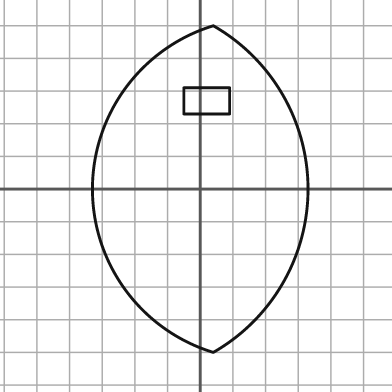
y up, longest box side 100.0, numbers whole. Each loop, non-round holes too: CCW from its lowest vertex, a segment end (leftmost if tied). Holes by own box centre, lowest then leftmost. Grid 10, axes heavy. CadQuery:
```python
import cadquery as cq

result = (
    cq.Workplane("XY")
    .moveTo(4.0, -50.0)
    .threePointArc((33.0, 0.0), (4.0, 50.0))
    .threePointArc((-33.0, 0.0), (4.0, -50.0))
    .close()
    .moveTo(-5.0, 23.0)
    .lineTo(9.0, 23.0)
    .lineTo(9.0, 31.0)
    .lineTo(-5.0, 31.0)
    .close()
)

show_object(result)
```